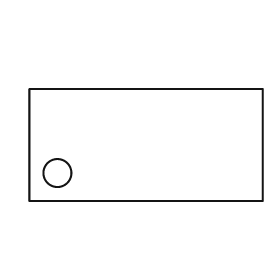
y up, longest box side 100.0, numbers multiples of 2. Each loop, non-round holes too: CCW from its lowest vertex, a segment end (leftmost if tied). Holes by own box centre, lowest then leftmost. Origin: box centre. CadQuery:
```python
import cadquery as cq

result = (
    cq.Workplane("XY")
    .moveTo(-50.0, -24.0)
    .lineTo(50.0, -24.0)
    .lineTo(50.0, 24.0)
    .lineTo(-50.0, 24.0)
    .close()
    .moveTo(-38.0, -12.0)
    .circle(6.0)
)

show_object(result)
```